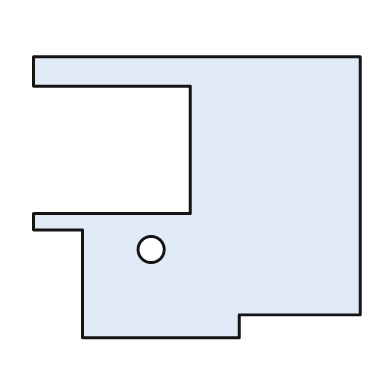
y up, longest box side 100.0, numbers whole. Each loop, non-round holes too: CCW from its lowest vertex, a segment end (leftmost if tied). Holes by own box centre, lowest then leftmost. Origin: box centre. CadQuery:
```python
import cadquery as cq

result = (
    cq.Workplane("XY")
    .moveTo(-35.0, -43.0)
    .lineTo(13.0, -43.0)
    .lineTo(13.0, -36.0)
    .lineTo(50.0, -36.0)
    .lineTo(50.0, 43.0)
    .lineTo(-50.0, 43.0)
    .lineTo(-50.0, 34.0)
    .lineTo(-2.0, 34.0)
    .lineTo(-2.0, -5.0)
    .lineTo(-50.0, -5.0)
    .lineTo(-50.0, -10.0)
    .lineTo(-35.0, -10.0)
    .close()
    .moveTo(-14.0, -16.0)
    .circle(4.0)
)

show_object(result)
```